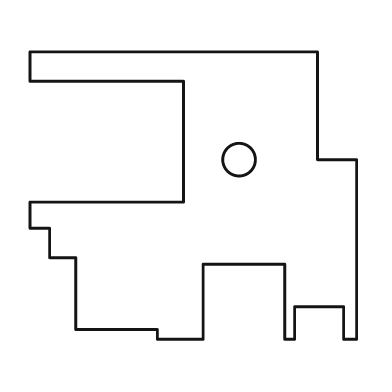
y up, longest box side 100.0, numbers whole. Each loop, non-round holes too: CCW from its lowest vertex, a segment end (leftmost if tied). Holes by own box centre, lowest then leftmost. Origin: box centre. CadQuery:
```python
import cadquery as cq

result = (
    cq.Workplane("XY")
    .moveTo(-11.0, -44.0)
    .lineTo(3.0, -44.0)
    .lineTo(3.0, -21.0)
    .lineTo(28.0, -21.0)
    .lineTo(28.0, -44.0)
    .lineTo(31.0, -44.0)
    .lineTo(31.0, -34.0)
    .lineTo(46.0, -34.0)
    .lineTo(46.0, -44.0)
    .lineTo(50.0, -44.0)
    .lineTo(50.0, 11.0)
    .lineTo(38.0, 11.0)
    .lineTo(38.0, 44.0)
    .lineTo(-50.0, 44.0)
    .lineTo(-50.0, 35.0)
    .lineTo(-3.0, 35.0)
    .lineTo(-3.0, -2.0)
    .lineTo(-50.0, -2.0)
    .lineTo(-50.0, -10.0)
    .lineTo(-44.0, -10.0)
    .lineTo(-44.0, -19.0)
    .lineTo(-36.0, -19.0)
    .lineTo(-36.0, -41.0)
    .lineTo(-11.0, -41.0)
    .close()
    .moveTo(14.0, 11.0)
    .circle(5.0)
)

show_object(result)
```